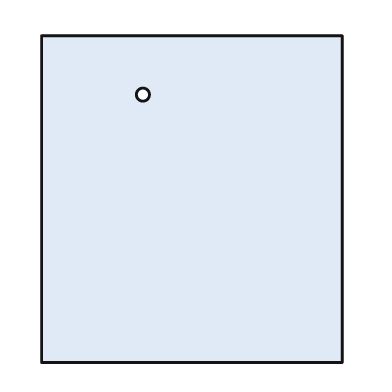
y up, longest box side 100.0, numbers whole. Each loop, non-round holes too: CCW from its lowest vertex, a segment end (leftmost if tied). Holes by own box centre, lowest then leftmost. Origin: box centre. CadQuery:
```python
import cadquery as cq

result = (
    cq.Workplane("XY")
    .moveTo(-46.0, -50.0)
    .lineTo(46.0, -50.0)
    .lineTo(46.0, 50.0)
    .lineTo(-46.0, 50.0)
    .close()
    .moveTo(-15.0, 32.0)
    .circle(2.0)
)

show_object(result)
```